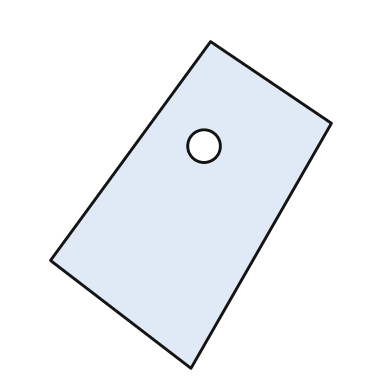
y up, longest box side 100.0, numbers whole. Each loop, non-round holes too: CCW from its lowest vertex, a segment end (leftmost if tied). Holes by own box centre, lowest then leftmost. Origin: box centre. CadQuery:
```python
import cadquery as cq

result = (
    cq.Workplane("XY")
    .moveTo(0.0, -50.0)
    .lineTo(43.0, 25.0)
    .lineTo(6.0, 50.0)
    .lineTo(-43.0, -17.0)
    .close()
    .moveTo(4.0, 18.0)
    .circle(5.0)
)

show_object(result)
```